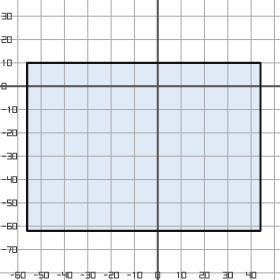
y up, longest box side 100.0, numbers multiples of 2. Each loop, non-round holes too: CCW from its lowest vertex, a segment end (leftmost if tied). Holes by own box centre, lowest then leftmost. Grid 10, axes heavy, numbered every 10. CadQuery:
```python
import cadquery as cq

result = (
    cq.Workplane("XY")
    .moveTo(-56.0, -62.0)
    .lineTo(44.0, -62.0)
    .lineTo(44.0, 10.0)
    .lineTo(-56.0, 10.0)
    .close()
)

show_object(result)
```